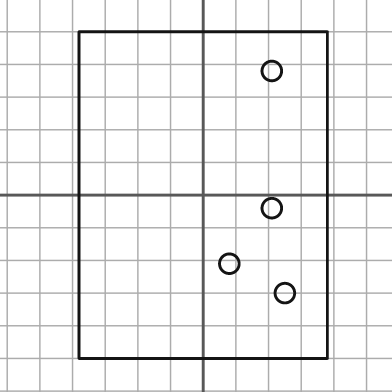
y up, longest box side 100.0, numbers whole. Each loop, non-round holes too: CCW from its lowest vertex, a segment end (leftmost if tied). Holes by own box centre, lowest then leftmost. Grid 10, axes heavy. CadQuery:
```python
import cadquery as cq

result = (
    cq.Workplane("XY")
    .moveTo(-38.0, -50.0)
    .lineTo(38.0, -50.0)
    .lineTo(38.0, 50.0)
    .lineTo(-38.0, 50.0)
    .close()
    .moveTo(25.0, -30.0)
    .circle(3.0)
    .moveTo(8.0, -21.0)
    .circle(3.0)
    .moveTo(21.0, -4.0)
    .circle(3.0)
    .moveTo(21.0, 38.0)
    .circle(3.0)
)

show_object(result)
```